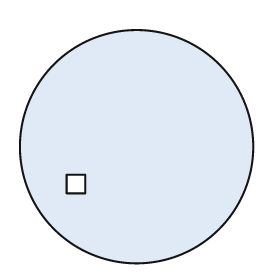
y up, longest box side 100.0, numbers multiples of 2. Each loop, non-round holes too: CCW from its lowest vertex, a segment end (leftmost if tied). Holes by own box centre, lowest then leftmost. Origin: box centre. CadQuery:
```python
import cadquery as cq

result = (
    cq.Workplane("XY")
    .moveTo(0.0, 0.0)
    .circle(50.0)
    .moveTo(-30.0, -20.0)
    .lineTo(-22.0, -20.0)
    .lineTo(-22.0, -12.0)
    .lineTo(-30.0, -12.0)
    .close()
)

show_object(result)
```